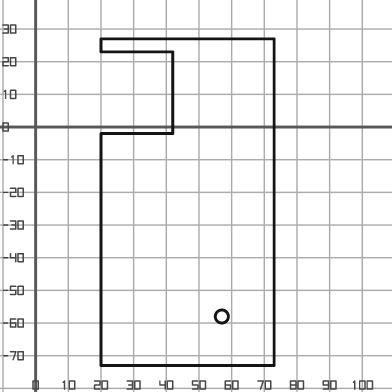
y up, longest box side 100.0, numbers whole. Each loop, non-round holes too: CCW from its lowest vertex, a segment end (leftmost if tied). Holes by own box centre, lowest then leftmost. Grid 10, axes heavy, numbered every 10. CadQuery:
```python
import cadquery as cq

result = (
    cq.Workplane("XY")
    .moveTo(20.0, -73.0)
    .lineTo(73.0, -73.0)
    .lineTo(73.0, 27.0)
    .lineTo(20.0, 27.0)
    .lineTo(20.0, 23.0)
    .lineTo(42.0, 23.0)
    .lineTo(42.0, -2.0)
    .lineTo(20.0, -2.0)
    .close()
    .moveTo(57.0, -58.0)
    .circle(2.0)
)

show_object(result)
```